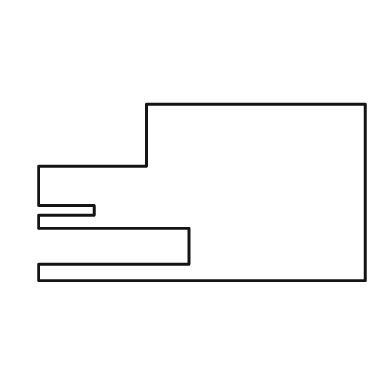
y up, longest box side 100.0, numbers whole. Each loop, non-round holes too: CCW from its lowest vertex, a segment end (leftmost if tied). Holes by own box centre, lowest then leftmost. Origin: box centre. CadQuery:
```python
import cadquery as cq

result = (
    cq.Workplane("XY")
    .moveTo(-50.0, -27.0)
    .lineTo(50.0, -27.0)
    .lineTo(50.0, 27.0)
    .lineTo(-17.0, 27.0)
    .lineTo(-17.0, 8.0)
    .lineTo(-50.0, 8.0)
    .lineTo(-50.0, -4.0)
    .lineTo(-33.0, -4.0)
    .lineTo(-33.0, -7.0)
    .lineTo(-50.0, -7.0)
    .lineTo(-50.0, -11.0)
    .lineTo(-4.0, -11.0)
    .lineTo(-4.0, -22.0)
    .lineTo(-50.0, -22.0)
    .close()
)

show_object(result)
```